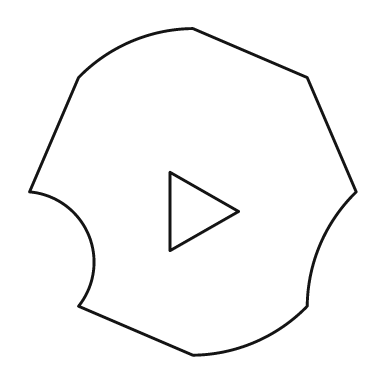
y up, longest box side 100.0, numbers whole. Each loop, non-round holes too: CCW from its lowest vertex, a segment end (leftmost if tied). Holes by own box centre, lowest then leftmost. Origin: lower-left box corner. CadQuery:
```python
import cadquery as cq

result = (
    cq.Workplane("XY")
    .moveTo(50.0, 0.0)
    .threePointArc((69.0, 4.0), (85.0, 15.0))
    .threePointArc((89.0, 34.0), (100.0, 50.0))
    .lineTo(85.0, 85.0)
    .lineTo(50.0, 100.0)
    .threePointArc((31.0, 96.0), (15.0, 85.0))
    .lineTo(0.0, 50.0)
    .threePointArc((18.0, 37.0), (15.0, 15.0))
    .close()
    .moveTo(43.0, 32.0)
    .lineTo(64.0, 44.0)
    .lineTo(43.0, 56.0)
    .close()
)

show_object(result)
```